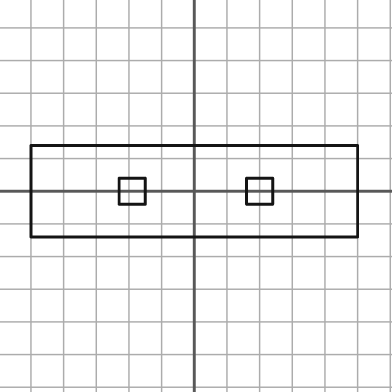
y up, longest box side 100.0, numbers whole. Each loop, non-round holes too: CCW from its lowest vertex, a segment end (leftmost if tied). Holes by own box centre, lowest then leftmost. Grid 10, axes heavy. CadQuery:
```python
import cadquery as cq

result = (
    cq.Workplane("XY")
    .moveTo(-50.0, -14.0)
    .lineTo(50.0, -14.0)
    .lineTo(50.0, 14.0)
    .lineTo(-50.0, 14.0)
    .close()
    .moveTo(-23.0, -4.0)
    .lineTo(-15.0, -4.0)
    .lineTo(-15.0, 4.0)
    .lineTo(-23.0, 4.0)
    .close()
    .moveTo(16.0, -4.0)
    .lineTo(24.0, -4.0)
    .lineTo(24.0, 4.0)
    .lineTo(16.0, 4.0)
    .close()
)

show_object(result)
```